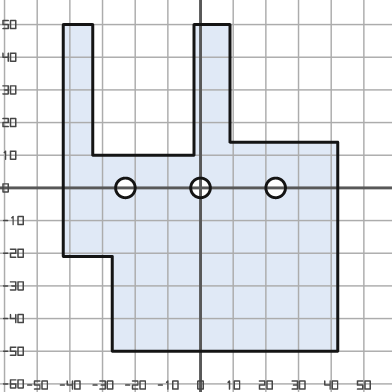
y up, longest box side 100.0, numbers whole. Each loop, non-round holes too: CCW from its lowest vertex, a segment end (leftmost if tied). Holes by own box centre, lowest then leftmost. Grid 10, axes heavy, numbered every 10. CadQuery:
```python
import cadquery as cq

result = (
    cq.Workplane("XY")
    .moveTo(-27.0, -50.0)
    .lineTo(42.0, -50.0)
    .lineTo(42.0, 14.0)
    .lineTo(9.0, 14.0)
    .lineTo(9.0, 50.0)
    .lineTo(-2.0, 50.0)
    .lineTo(-2.0, 10.0)
    .lineTo(-33.0, 10.0)
    .lineTo(-33.0, 50.0)
    .lineTo(-42.0, 50.0)
    .lineTo(-42.0, -21.0)
    .lineTo(-27.0, -21.0)
    .close()
    .moveTo(-23.0, 0.0)
    .circle(3.0)
    .moveTo(0.0, 0.0)
    .circle(3.0)
    .moveTo(23.0, 0.0)
    .circle(3.0)
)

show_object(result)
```